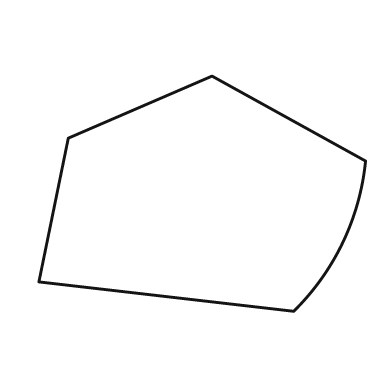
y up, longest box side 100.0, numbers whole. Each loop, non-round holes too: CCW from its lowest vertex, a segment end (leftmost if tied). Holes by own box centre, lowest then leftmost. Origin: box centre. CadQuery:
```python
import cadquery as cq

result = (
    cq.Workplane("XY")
    .moveTo(28.0, -36.0)
    .threePointArc((43.0, -15.0), (50.0, 10.0))
    .lineTo(3.0, 36.0)
    .lineTo(-41.0, 17.0)
    .lineTo(-50.0, -27.0)
    .close()
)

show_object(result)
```